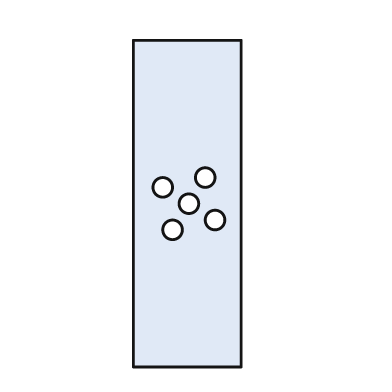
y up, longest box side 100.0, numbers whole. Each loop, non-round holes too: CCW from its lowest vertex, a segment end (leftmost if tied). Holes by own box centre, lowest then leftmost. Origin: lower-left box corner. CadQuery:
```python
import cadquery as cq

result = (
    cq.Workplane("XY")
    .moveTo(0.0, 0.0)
    .lineTo(33.0, 0.0)
    .lineTo(33.0, 100.0)
    .lineTo(0.0, 100.0)
    .close()
    .moveTo(12.0, 42.0)
    .circle(3.0)
    .moveTo(25.0, 45.0)
    .circle(3.0)
    .moveTo(17.0, 50.0)
    .circle(3.0)
    .moveTo(9.0, 55.0)
    .circle(3.0)
    .moveTo(22.0, 58.0)
    .circle(3.0)
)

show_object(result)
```